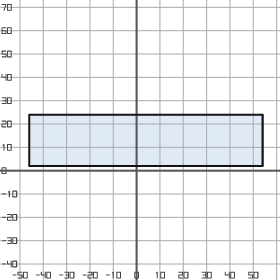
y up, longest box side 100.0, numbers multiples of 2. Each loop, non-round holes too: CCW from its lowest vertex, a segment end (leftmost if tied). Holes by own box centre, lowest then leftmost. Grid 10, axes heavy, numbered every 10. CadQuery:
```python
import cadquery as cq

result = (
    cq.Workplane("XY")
    .moveTo(-46.0, 2.0)
    .lineTo(54.0, 2.0)
    .lineTo(54.0, 24.0)
    .lineTo(-46.0, 24.0)
    .close()
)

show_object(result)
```